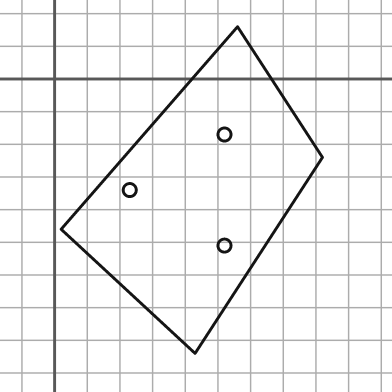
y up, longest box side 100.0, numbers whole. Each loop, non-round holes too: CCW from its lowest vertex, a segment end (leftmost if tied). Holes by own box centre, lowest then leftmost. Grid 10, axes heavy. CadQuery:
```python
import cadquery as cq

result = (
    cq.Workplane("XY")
    .moveTo(43.0, -84.0)
    .lineTo(82.0, -24.0)
    .lineTo(56.0, 16.0)
    .lineTo(2.0, -46.0)
    .close()
    .moveTo(52.0, -51.0)
    .circle(2.0)
    .moveTo(23.0, -34.0)
    .circle(2.0)
    .moveTo(52.0, -17.0)
    .circle(2.0)
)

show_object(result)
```